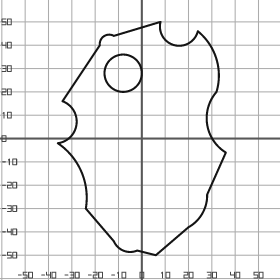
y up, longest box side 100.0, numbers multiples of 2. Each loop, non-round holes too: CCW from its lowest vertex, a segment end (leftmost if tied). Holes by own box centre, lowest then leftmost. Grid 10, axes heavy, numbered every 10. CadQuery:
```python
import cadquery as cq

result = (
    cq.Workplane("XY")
    .moveTo(6.0, -50.0)
    .lineTo(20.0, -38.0)
    .threePointArc((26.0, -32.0), (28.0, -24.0))
    .lineTo(36.0, -6.0)
    .threePointArc((28.0, 6.0), (32.0, 20.0))
    .threePointArc((32.0, 34.0), (24.0, 46.0))
    .threePointArc((14.0, 40.0), (8.0, 50.0))
    .lineTo(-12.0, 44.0)
    .threePointArc((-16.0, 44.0), (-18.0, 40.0))
    .lineTo(-34.0, 16.0)
    .threePointArc((-28.0, 6.0), (-36.0, -2.0))
    .threePointArc((-26.0, -14.0), (-24.0, -30.0))
    .lineTo(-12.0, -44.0)
    .threePointArc((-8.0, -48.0), (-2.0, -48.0))
    .close()
    .moveTo(-8.0, 28.0)
    .circle(8.0)
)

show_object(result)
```